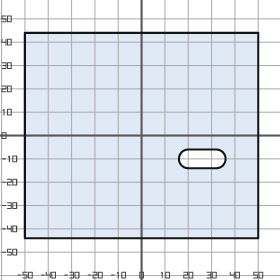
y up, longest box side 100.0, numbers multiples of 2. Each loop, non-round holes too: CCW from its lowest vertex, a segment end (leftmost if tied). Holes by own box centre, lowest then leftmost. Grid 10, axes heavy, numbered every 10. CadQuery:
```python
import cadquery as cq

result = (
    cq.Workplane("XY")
    .moveTo(-50.0, -44.0)
    .lineTo(50.0, -44.0)
    .lineTo(50.0, 44.0)
    .lineTo(-50.0, 44.0)
    .close()
    .moveTo(20.0, -14.0)
    .lineTo(32.0, -14.0)
    .threePointArc((36.0, -10.0), (32.0, -6.0))
    .lineTo(20.0, -6.0)
    .threePointArc((16.0, -10.0), (20.0, -14.0))
    .close()
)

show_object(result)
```